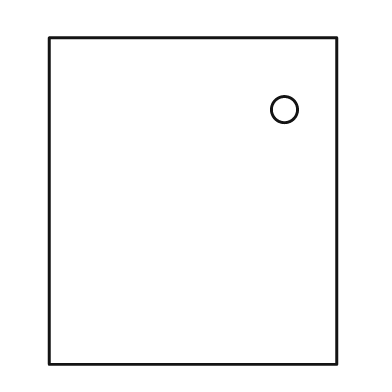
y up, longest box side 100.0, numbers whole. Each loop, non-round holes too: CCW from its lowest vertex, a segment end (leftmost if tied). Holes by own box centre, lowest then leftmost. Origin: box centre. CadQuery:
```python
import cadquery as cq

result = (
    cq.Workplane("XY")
    .moveTo(-44.0, -50.0)
    .lineTo(44.0, -50.0)
    .lineTo(44.0, 50.0)
    .lineTo(-44.0, 50.0)
    .close()
    .moveTo(28.0, 28.0)
    .circle(4.0)
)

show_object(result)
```